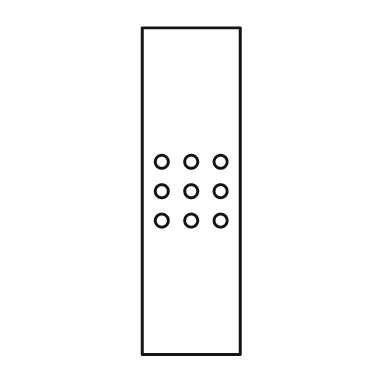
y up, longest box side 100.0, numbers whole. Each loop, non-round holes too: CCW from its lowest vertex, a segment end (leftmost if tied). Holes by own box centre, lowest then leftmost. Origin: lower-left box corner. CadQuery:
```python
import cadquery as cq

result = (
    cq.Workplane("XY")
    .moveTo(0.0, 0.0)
    .lineTo(30.0, 0.0)
    .lineTo(30.0, 100.0)
    .lineTo(0.0, 100.0)
    .close()
    .moveTo(6.0, 41.0)
    .circle(2.0)
    .moveTo(15.0, 41.0)
    .circle(2.0)
    .moveTo(24.0, 41.0)
    .circle(2.0)
    .moveTo(6.0, 50.0)
    .circle(2.0)
    .moveTo(15.0, 50.0)
    .circle(2.0)
    .moveTo(24.0, 50.0)
    .circle(2.0)
    .moveTo(6.0, 59.0)
    .circle(2.0)
    .moveTo(15.0, 59.0)
    .circle(2.0)
    .moveTo(24.0, 59.0)
    .circle(2.0)
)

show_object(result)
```